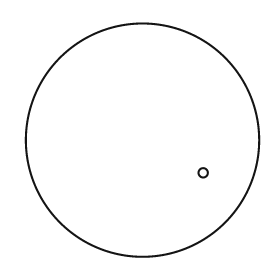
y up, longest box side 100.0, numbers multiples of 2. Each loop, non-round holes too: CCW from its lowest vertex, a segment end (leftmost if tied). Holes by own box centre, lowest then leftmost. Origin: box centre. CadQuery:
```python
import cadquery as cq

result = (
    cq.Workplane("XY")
    .moveTo(0.0, 0.0)
    .circle(50.0)
    .moveTo(26.0, -14.0)
    .circle(2.0)
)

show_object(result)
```